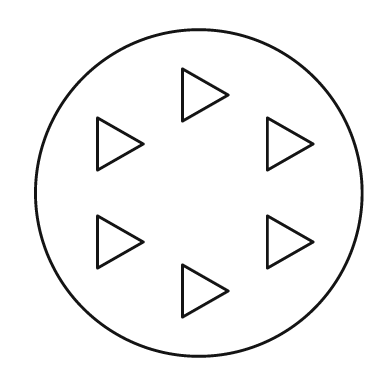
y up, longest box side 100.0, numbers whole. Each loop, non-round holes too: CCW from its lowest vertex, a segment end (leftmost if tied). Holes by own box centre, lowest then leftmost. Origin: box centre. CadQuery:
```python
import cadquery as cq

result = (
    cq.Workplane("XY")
    .moveTo(0.0, 0.0)
    .circle(50.0)
    .moveTo(-5.0, -38.0)
    .lineTo(9.0, -30.0)
    .lineTo(-5.0, -22.0)
    .close()
    .moveTo(-31.0, -23.0)
    .lineTo(-17.0, -15.0)
    .lineTo(-31.0, -7.0)
    .close()
    .moveTo(21.0, -23.0)
    .lineTo(35.0, -15.0)
    .lineTo(21.0, -7.0)
    .close()
    .moveTo(-31.0, 7.0)
    .lineTo(-17.0, 15.0)
    .lineTo(-31.0, 23.0)
    .close()
    .moveTo(21.0, 7.0)
    .lineTo(35.0, 15.0)
    .lineTo(21.0, 23.0)
    .close()
    .moveTo(-5.0, 22.0)
    .lineTo(9.0, 30.0)
    .lineTo(-5.0, 38.0)
    .close()
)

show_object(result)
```